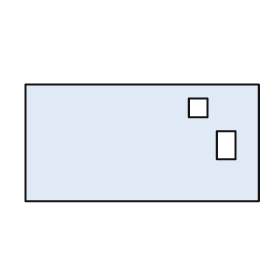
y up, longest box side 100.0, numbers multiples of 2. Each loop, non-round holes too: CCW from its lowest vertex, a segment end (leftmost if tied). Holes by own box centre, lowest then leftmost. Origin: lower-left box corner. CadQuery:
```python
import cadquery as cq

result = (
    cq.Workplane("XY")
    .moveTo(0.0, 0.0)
    .lineTo(100.0, 0.0)
    .lineTo(100.0, 50.0)
    .lineTo(0.0, 50.0)
    .close()
    .moveTo(82.0, 18.0)
    .lineTo(90.0, 18.0)
    .lineTo(90.0, 30.0)
    .lineTo(82.0, 30.0)
    .close()
    .moveTo(70.0, 36.0)
    .lineTo(78.0, 36.0)
    .lineTo(78.0, 44.0)
    .lineTo(70.0, 44.0)
    .close()
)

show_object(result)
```